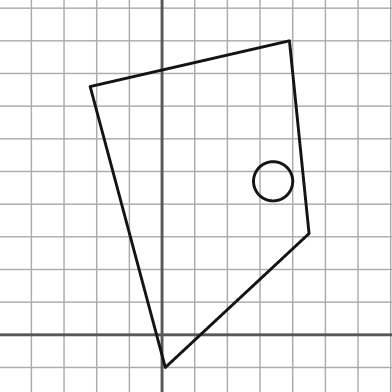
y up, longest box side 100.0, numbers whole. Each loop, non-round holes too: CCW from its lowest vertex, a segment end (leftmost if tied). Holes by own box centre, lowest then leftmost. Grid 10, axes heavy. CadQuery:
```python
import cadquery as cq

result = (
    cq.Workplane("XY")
    .moveTo(1.0, -10.0)
    .lineTo(45.0, 31.0)
    .lineTo(39.0, 90.0)
    .lineTo(-22.0, 76.0)
    .close()
    .moveTo(34.0, 47.0)
    .circle(6.0)
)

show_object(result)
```